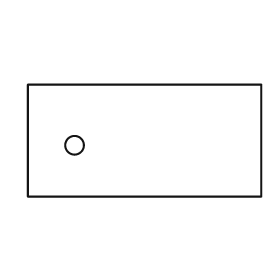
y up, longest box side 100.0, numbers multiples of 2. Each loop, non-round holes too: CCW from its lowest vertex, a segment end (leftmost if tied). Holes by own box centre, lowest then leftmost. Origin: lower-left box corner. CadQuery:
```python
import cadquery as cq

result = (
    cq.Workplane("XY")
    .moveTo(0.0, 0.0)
    .lineTo(100.0, 0.0)
    .lineTo(100.0, 48.0)
    .lineTo(0.0, 48.0)
    .close()
    .moveTo(20.0, 22.0)
    .circle(4.0)
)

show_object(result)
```